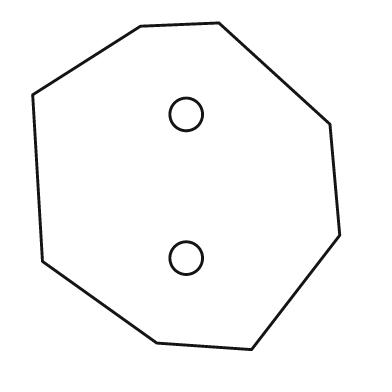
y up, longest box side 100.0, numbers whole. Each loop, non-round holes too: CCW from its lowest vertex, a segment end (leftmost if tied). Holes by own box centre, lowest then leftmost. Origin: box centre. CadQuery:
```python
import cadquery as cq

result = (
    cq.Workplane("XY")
    .moveTo(20.0, -50.0)
    .lineTo(47.0, -15.0)
    .lineTo(44.0, 19.0)
    .lineTo(10.0, 50.0)
    .lineTo(-14.0, 49.0)
    .lineTo(-47.0, 28.0)
    .lineTo(-44.0, -23.0)
    .lineTo(-9.0, -48.0)
    .close()
    .moveTo(0.0, -22.0)
    .circle(5.0)
    .moveTo(0.0, 22.0)
    .circle(5.0)
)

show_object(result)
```